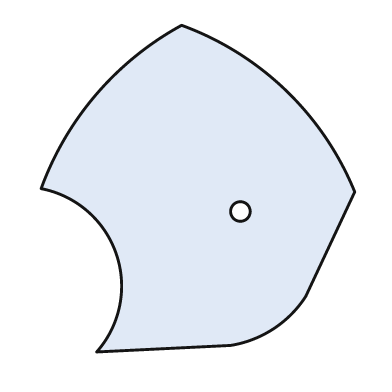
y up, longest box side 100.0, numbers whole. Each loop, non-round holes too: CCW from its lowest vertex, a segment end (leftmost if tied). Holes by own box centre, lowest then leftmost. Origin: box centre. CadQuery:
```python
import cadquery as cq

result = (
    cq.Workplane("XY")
    .moveTo(-31.0, -50.0)
    .lineTo(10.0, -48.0)
    .threePointArc((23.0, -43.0), (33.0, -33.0))
    .lineTo(48.0, -1.0)
    .threePointArc((27.0, 30.0), (-5.0, 50.0))
    .threePointArc((-31.0, 29.0), (-48.0, 0.0))
    .threePointArc((-25.0, -20.0), (-31.0, -50.0))
    .close()
    .moveTo(13.0, -7.0)
    .circle(3.0)
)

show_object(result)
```